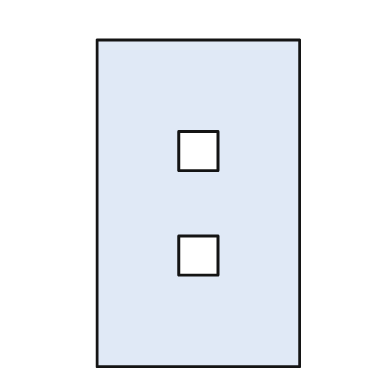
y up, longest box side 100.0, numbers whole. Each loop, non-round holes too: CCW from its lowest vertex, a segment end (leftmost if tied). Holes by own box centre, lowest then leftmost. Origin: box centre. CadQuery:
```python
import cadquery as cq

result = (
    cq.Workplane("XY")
    .moveTo(-31.0, -50.0)
    .lineTo(31.0, -50.0)
    .lineTo(31.0, 50.0)
    .lineTo(-31.0, 50.0)
    .close()
    .moveTo(-6.0, -22.0)
    .lineTo(6.0, -22.0)
    .lineTo(6.0, -10.0)
    .lineTo(-6.0, -10.0)
    .close()
    .moveTo(-6.0, 10.0)
    .lineTo(6.0, 10.0)
    .lineTo(6.0, 22.0)
    .lineTo(-6.0, 22.0)
    .close()
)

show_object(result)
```